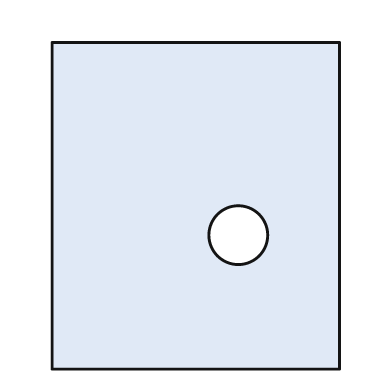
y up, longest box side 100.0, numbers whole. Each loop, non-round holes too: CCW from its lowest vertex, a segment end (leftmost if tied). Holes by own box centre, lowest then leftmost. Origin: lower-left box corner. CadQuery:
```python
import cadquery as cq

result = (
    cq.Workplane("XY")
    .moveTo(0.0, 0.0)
    .lineTo(88.0, 0.0)
    .lineTo(88.0, 100.0)
    .lineTo(0.0, 100.0)
    .close()
    .moveTo(57.0, 41.0)
    .circle(9.0)
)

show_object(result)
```